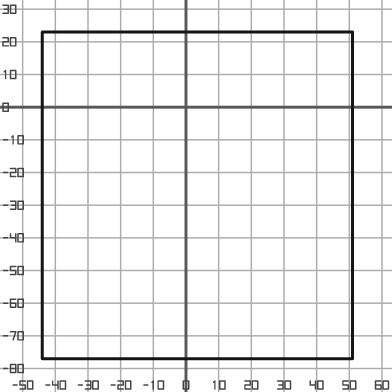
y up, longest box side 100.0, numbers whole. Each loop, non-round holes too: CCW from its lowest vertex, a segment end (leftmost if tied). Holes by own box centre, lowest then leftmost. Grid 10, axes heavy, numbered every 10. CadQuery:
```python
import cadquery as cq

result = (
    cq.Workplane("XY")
    .moveTo(-44.0, -77.0)
    .lineTo(51.0, -77.0)
    .lineTo(51.0, 23.0)
    .lineTo(-44.0, 23.0)
    .close()
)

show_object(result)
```